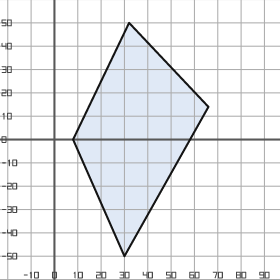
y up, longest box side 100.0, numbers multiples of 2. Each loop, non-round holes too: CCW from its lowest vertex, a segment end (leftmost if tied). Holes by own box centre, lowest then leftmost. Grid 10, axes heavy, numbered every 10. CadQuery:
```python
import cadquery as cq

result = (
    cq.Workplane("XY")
    .moveTo(30.0, -50.0)
    .lineTo(66.0, 14.0)
    .lineTo(32.0, 50.0)
    .lineTo(8.0, 0.0)
    .close()
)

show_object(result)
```